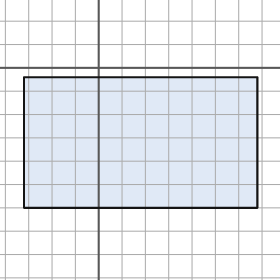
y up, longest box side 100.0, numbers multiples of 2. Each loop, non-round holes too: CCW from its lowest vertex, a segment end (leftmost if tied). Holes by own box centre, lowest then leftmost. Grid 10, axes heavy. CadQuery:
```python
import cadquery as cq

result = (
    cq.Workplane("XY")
    .moveTo(-32.0, -60.0)
    .lineTo(68.0, -60.0)
    .lineTo(68.0, -4.0)
    .lineTo(-32.0, -4.0)
    .close()
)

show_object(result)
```